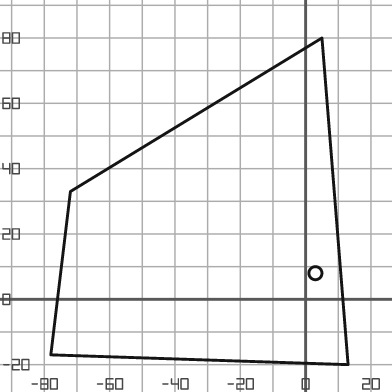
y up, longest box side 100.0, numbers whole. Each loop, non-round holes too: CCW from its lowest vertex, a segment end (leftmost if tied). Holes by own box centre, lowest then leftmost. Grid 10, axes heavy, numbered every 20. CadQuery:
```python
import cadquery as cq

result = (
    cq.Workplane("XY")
    .moveTo(13.0, -20.0)
    .lineTo(5.0, 80.0)
    .lineTo(-72.0, 33.0)
    .lineTo(-78.0, -17.0)
    .close()
    .moveTo(3.0, 8.0)
    .circle(2.0)
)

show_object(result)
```